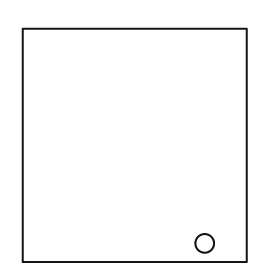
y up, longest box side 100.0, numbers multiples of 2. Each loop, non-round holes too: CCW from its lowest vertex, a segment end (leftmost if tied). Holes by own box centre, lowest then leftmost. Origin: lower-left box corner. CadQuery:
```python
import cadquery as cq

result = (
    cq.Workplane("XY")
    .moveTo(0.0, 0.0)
    .lineTo(96.0, 0.0)
    .lineTo(96.0, 100.0)
    .lineTo(0.0, 100.0)
    .close()
    .moveTo(78.0, 8.0)
    .circle(4.0)
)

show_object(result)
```